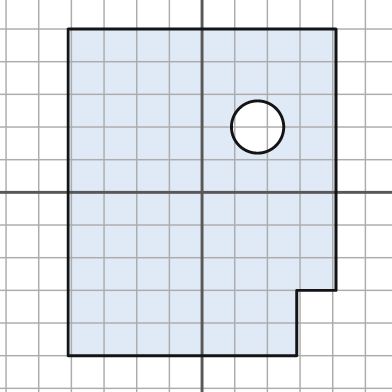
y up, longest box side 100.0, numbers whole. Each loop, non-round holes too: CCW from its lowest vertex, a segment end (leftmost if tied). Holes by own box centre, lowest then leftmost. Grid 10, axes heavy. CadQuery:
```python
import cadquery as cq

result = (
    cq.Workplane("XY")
    .moveTo(-41.0, -50.0)
    .lineTo(29.0, -50.0)
    .lineTo(29.0, -30.0)
    .lineTo(41.0, -30.0)
    .lineTo(41.0, 50.0)
    .lineTo(-41.0, 50.0)
    .close()
    .moveTo(17.0, 20.0)
    .circle(8.0)
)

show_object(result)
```